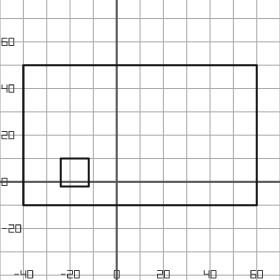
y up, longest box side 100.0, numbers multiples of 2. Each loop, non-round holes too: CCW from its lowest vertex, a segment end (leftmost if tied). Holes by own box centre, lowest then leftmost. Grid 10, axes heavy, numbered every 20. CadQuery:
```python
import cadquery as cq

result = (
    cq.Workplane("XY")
    .moveTo(-40.0, -10.0)
    .lineTo(60.0, -10.0)
    .lineTo(60.0, 50.0)
    .lineTo(-40.0, 50.0)
    .close()
    .moveTo(-24.0, -2.0)
    .lineTo(-12.0, -2.0)
    .lineTo(-12.0, 10.0)
    .lineTo(-24.0, 10.0)
    .close()
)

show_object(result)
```